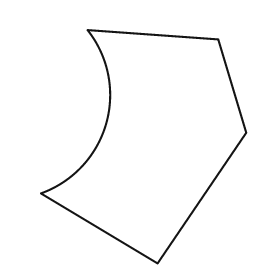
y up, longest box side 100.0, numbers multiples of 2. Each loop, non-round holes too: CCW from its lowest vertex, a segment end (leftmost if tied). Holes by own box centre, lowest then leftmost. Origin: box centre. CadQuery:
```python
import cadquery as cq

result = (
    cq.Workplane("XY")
    .moveTo(6.0, -50.0)
    .lineTo(44.0, 6.0)
    .lineTo(32.0, 46.0)
    .lineTo(-24.0, 50.0)
    .threePointArc((-16.0, 10.0), (-44.0, -20.0))
    .close()
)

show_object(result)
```